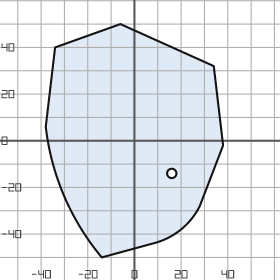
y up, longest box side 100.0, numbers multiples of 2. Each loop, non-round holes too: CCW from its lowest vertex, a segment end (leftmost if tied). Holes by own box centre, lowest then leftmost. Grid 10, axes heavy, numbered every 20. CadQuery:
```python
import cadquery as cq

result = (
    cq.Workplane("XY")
    .moveTo(-14.0, -50.0)
    .lineTo(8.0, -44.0)
    .threePointArc((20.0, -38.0), (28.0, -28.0))
    .lineTo(38.0, -2.0)
    .lineTo(34.0, 32.0)
    .lineTo(-6.0, 50.0)
    .lineTo(-34.0, 40.0)
    .lineTo(-38.0, 6.0)
    .threePointArc((-30.0, -24.0), (-14.0, -50.0))
    .close()
    .moveTo(16.0, -14.0)
    .circle(2.0)
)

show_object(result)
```